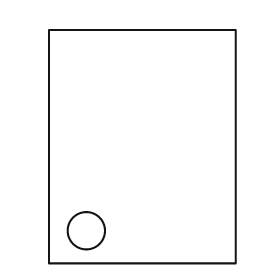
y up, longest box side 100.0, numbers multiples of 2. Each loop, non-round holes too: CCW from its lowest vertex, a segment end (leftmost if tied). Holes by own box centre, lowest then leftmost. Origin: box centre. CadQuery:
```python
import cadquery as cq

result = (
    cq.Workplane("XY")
    .moveTo(-40.0, -50.0)
    .lineTo(40.0, -50.0)
    .lineTo(40.0, 50.0)
    .lineTo(-40.0, 50.0)
    .close()
    .moveTo(-24.0, -36.0)
    .circle(8.0)
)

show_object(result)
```